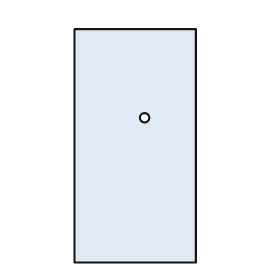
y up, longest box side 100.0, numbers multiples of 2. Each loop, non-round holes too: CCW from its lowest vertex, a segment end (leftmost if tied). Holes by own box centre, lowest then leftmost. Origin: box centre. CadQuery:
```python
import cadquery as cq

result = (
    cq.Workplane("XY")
    .moveTo(-26.0, -50.0)
    .lineTo(26.0, -50.0)
    .lineTo(26.0, 50.0)
    .lineTo(-26.0, 50.0)
    .close()
    .moveTo(4.0, 12.0)
    .circle(2.0)
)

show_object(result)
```